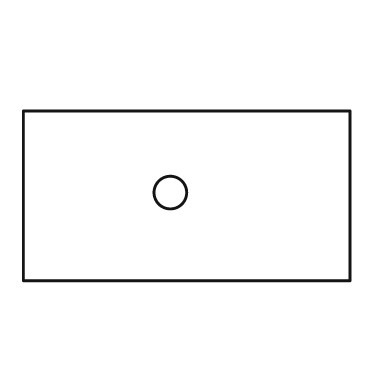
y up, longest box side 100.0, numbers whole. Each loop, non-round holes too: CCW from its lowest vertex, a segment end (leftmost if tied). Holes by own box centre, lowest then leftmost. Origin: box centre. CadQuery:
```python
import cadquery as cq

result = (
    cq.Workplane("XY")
    .moveTo(-50.0, -26.0)
    .lineTo(50.0, -26.0)
    .lineTo(50.0, 26.0)
    .lineTo(-50.0, 26.0)
    .close()
    .moveTo(-5.0, 1.0)
    .circle(5.0)
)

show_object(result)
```